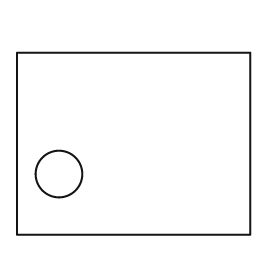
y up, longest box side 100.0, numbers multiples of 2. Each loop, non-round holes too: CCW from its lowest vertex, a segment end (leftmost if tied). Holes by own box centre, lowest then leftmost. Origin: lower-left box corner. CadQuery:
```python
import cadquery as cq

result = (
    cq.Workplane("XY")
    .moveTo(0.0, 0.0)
    .lineTo(100.0, 0.0)
    .lineTo(100.0, 78.0)
    .lineTo(0.0, 78.0)
    .close()
    .moveTo(18.0, 26.0)
    .circle(10.0)
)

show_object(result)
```